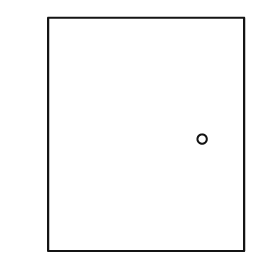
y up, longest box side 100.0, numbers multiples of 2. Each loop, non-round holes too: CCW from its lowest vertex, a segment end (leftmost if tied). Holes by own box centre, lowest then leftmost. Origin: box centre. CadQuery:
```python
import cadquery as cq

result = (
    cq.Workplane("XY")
    .moveTo(-42.0, -50.0)
    .lineTo(42.0, -50.0)
    .lineTo(42.0, 50.0)
    .lineTo(-42.0, 50.0)
    .close()
    .moveTo(24.0, -2.0)
    .circle(2.0)
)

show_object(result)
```